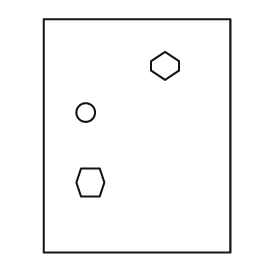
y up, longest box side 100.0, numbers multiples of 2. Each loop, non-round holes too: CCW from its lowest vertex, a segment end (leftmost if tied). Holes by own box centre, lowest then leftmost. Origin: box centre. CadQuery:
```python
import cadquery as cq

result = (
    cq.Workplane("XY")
    .moveTo(-40.0, -50.0)
    .lineTo(40.0, -50.0)
    .lineTo(40.0, 50.0)
    .lineTo(-40.0, 50.0)
    .close()
    .moveTo(-24.0, -26.0)
    .lineTo(-16.0, -26.0)
    .lineTo(-14.0, -20.0)
    .lineTo(-16.0, -14.0)
    .lineTo(-24.0, -14.0)
    .lineTo(-26.0, -20.0)
    .close()
    .moveTo(-22.0, 10.0)
    .circle(4.0)
    .moveTo(12.0, 24.0)
    .lineTo(18.0, 28.0)
    .lineTo(18.0, 32.0)
    .lineTo(12.0, 36.0)
    .lineTo(6.0, 32.0)
    .lineTo(6.0, 28.0)
    .close()
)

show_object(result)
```